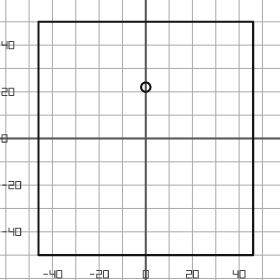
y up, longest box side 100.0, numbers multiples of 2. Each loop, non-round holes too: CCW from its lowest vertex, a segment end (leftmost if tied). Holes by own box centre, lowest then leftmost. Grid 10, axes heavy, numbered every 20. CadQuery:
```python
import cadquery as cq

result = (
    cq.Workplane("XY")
    .moveTo(-46.0, -50.0)
    .lineTo(46.0, -50.0)
    .lineTo(46.0, 50.0)
    .lineTo(-46.0, 50.0)
    .close()
    .moveTo(0.0, 22.0)
    .circle(2.0)
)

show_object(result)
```